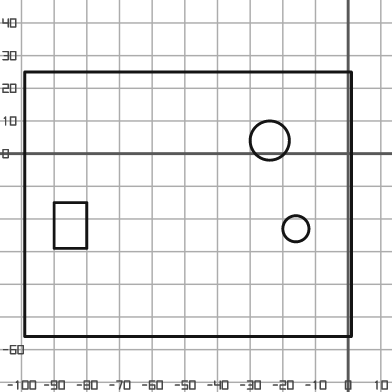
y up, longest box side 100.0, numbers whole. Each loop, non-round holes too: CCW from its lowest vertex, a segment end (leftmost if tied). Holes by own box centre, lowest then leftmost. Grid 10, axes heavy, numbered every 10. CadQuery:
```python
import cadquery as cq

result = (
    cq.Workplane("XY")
    .moveTo(-99.0, -56.0)
    .lineTo(1.0, -56.0)
    .lineTo(1.0, 25.0)
    .lineTo(-99.0, 25.0)
    .close()
    .moveTo(-16.0, -23.0)
    .circle(4.0)
    .moveTo(-90.0, -29.0)
    .lineTo(-80.0, -29.0)
    .lineTo(-80.0, -15.0)
    .lineTo(-90.0, -15.0)
    .close()
    .moveTo(-24.0, 4.0)
    .circle(6.0)
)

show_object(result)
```